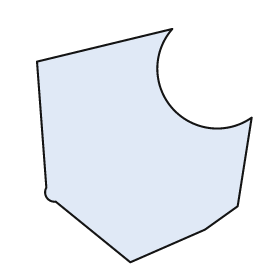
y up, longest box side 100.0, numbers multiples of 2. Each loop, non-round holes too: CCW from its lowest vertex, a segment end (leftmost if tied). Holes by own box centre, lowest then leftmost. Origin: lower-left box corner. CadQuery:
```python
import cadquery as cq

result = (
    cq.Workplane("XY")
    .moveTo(40.0, 0.0)
    .lineTo(72.0, 14.0)
    .lineTo(86.0, 24.0)
    .lineTo(92.0, 62.0)
    .threePointArc((58.0, 66.0), (58.0, 100.0))
    .lineTo(0.0, 86.0)
    .lineTo(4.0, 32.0)
    .threePointArc((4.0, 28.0), (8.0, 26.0))
    .close()
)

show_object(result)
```